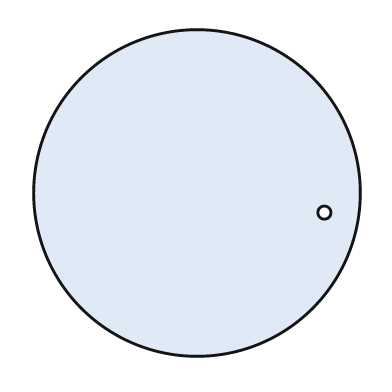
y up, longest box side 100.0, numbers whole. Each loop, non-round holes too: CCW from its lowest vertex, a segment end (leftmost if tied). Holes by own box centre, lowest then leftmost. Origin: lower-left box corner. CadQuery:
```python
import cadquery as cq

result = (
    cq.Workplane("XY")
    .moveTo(50.0, 50.0)
    .circle(50.0)
    .moveTo(89.0, 44.0)
    .circle(2.0)
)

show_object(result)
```